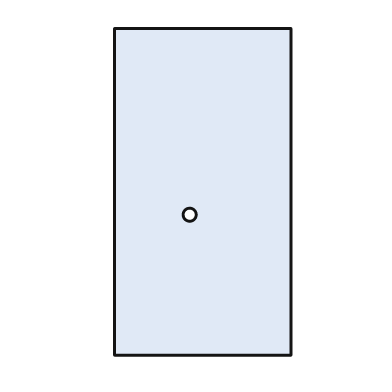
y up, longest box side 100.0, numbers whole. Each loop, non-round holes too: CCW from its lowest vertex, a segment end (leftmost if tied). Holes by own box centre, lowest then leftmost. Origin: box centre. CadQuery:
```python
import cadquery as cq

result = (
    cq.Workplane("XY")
    .moveTo(-27.0, -50.0)
    .lineTo(27.0, -50.0)
    .lineTo(27.0, 50.0)
    .lineTo(-27.0, 50.0)
    .close()
    .moveTo(-4.0, -7.0)
    .circle(2.0)
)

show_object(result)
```